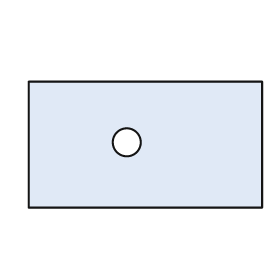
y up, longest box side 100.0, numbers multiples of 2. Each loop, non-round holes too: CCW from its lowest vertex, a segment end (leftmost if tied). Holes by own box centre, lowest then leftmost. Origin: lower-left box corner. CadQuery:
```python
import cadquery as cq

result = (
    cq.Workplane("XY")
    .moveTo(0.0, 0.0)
    .lineTo(100.0, 0.0)
    .lineTo(100.0, 54.0)
    .lineTo(0.0, 54.0)
    .close()
    .moveTo(42.0, 28.0)
    .circle(6.0)
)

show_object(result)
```